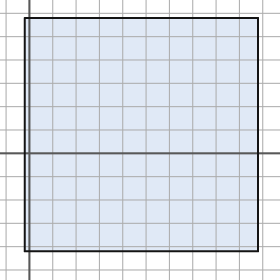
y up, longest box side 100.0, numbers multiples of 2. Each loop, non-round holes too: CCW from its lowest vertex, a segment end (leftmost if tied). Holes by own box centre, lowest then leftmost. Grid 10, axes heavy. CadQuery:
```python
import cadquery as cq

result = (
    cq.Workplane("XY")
    .moveTo(-2.0, -42.0)
    .lineTo(98.0, -42.0)
    .lineTo(98.0, 58.0)
    .lineTo(-2.0, 58.0)
    .close()
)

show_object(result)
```